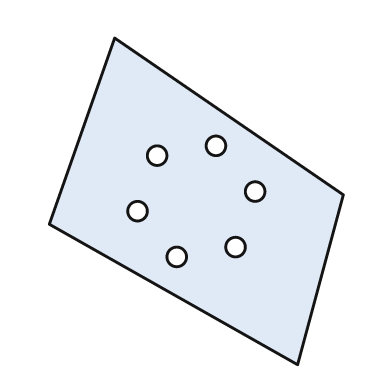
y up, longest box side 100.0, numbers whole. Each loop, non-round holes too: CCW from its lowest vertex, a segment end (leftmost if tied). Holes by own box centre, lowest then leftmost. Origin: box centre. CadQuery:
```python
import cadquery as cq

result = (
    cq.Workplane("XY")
    .moveTo(31.0, -50.0)
    .lineTo(45.0, 2.0)
    .lineTo(-25.0, 50.0)
    .lineTo(-45.0, -7.0)
    .close()
    .moveTo(-6.0, -17.0)
    .circle(3.0)
    .moveTo(12.0, -14.0)
    .circle(3.0)
    .moveTo(-18.0, -3.0)
    .circle(3.0)
    .moveTo(18.0, 3.0)
    .circle(3.0)
    .moveTo(-12.0, 14.0)
    .circle(3.0)
    .moveTo(6.0, 17.0)
    .circle(3.0)
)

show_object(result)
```